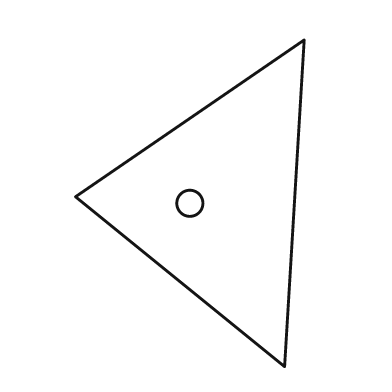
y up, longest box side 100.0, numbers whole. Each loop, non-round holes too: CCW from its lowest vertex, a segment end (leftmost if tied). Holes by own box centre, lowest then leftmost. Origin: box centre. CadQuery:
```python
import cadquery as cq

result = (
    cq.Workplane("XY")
    .moveTo(29.0, -50.0)
    .lineTo(35.0, 50.0)
    .lineTo(-35.0, 2.0)
    .close()
    .moveTo(0.0, 0.0)
    .circle(4.0)
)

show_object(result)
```